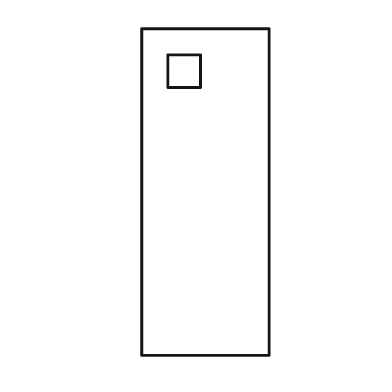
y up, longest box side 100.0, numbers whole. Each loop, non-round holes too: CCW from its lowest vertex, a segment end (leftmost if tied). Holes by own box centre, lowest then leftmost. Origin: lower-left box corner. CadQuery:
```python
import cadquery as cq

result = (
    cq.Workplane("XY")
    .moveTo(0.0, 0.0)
    .lineTo(39.0, 0.0)
    .lineTo(39.0, 100.0)
    .lineTo(0.0, 100.0)
    .close()
    .moveTo(8.0, 82.0)
    .lineTo(18.0, 82.0)
    .lineTo(18.0, 92.0)
    .lineTo(8.0, 92.0)
    .close()
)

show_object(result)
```